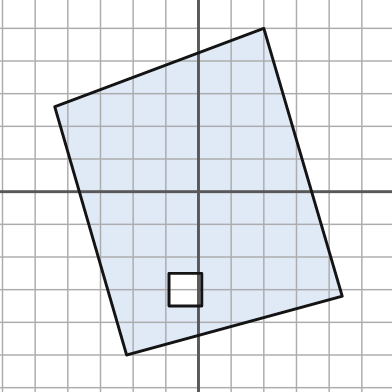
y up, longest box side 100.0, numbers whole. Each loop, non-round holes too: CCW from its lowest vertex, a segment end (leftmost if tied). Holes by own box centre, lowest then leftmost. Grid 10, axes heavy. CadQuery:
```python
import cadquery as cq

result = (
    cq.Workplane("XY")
    .moveTo(-22.0, -50.0)
    .lineTo(44.0, -32.0)
    .lineTo(20.0, 50.0)
    .lineTo(-44.0, 26.0)
    .close()
    .moveTo(-9.0, -35.0)
    .lineTo(1.0, -35.0)
    .lineTo(1.0, -25.0)
    .lineTo(-9.0, -25.0)
    .close()
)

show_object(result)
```